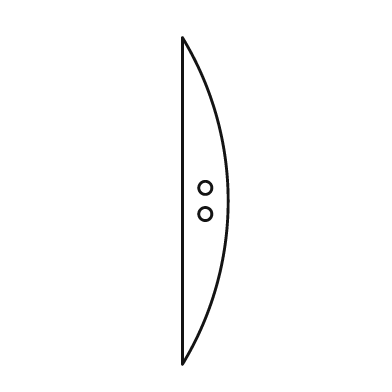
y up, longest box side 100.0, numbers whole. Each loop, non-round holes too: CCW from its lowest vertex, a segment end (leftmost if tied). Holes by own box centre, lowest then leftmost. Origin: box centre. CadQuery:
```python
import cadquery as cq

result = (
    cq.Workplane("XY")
    .moveTo(-7.0, -50.0)
    .threePointArc((7.0, 0.0), (-7.0, 50.0))
    .close()
    .moveTo(0.0, -4.0)
    .circle(2.0)
    .moveTo(0.0, 4.0)
    .circle(2.0)
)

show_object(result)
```